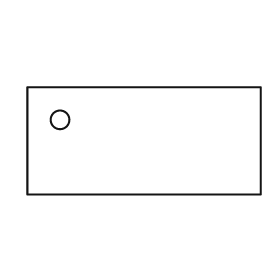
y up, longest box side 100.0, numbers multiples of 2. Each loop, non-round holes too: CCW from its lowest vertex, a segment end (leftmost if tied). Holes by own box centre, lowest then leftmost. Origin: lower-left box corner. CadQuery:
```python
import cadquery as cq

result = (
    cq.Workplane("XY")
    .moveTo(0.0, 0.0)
    .lineTo(100.0, 0.0)
    .lineTo(100.0, 46.0)
    .lineTo(0.0, 46.0)
    .close()
    .moveTo(14.0, 32.0)
    .circle(4.0)
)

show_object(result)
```